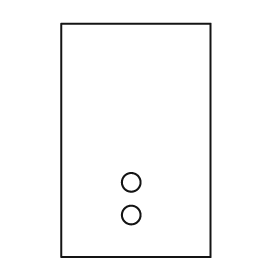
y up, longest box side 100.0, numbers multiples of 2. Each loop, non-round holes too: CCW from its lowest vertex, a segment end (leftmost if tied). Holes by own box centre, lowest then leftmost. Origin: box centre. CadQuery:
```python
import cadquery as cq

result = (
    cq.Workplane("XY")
    .moveTo(-32.0, -50.0)
    .lineTo(32.0, -50.0)
    .lineTo(32.0, 50.0)
    .lineTo(-32.0, 50.0)
    .close()
    .moveTo(-2.0, -32.0)
    .circle(4.0)
    .moveTo(-2.0, -18.0)
    .circle(4.0)
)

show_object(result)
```